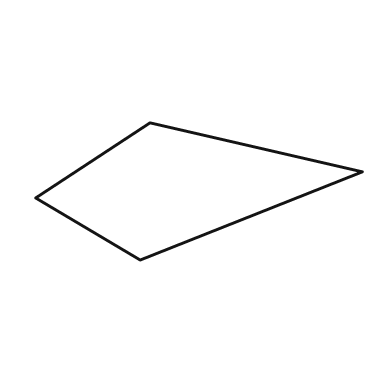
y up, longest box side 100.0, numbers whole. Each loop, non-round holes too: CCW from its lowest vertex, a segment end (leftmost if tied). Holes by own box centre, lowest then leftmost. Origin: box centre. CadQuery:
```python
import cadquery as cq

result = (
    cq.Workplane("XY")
    .moveTo(-18.0, -21.0)
    .lineTo(50.0, 6.0)
    .lineTo(-15.0, 21.0)
    .lineTo(-50.0, -2.0)
    .close()
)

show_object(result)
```